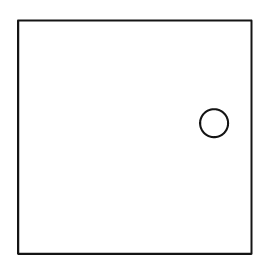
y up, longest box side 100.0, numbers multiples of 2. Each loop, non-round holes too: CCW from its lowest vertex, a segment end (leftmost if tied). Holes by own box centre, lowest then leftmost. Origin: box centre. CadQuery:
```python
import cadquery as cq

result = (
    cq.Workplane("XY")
    .moveTo(-50.0, -50.0)
    .lineTo(50.0, -50.0)
    .lineTo(50.0, 50.0)
    .lineTo(-50.0, 50.0)
    .close()
    .moveTo(34.0, 6.0)
    .circle(6.0)
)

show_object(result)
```